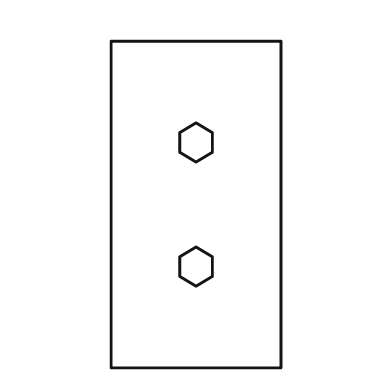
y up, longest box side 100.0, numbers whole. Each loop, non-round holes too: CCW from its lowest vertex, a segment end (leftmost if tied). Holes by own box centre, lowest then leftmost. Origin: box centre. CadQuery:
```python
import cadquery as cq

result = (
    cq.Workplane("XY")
    .moveTo(-26.0, -50.0)
    .lineTo(26.0, -50.0)
    .lineTo(26.0, 50.0)
    .lineTo(-26.0, 50.0)
    .close()
    .moveTo(0.0, -25.0)
    .lineTo(5.0, -22.0)
    .lineTo(5.0, -16.0)
    .lineTo(0.0, -13.0)
    .lineTo(-5.0, -16.0)
    .lineTo(-5.0, -22.0)
    .close()
    .moveTo(0.0, 13.0)
    .lineTo(5.0, 16.0)
    .lineTo(5.0, 22.0)
    .lineTo(0.0, 25.0)
    .lineTo(-5.0, 22.0)
    .lineTo(-5.0, 16.0)
    .close()
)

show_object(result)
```